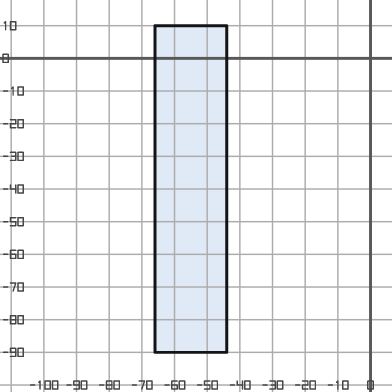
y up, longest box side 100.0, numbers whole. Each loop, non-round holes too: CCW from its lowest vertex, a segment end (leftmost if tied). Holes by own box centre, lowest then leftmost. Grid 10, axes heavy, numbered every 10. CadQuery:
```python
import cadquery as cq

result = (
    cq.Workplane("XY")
    .moveTo(-66.0, -90.0)
    .lineTo(-44.0, -90.0)
    .lineTo(-44.0, 10.0)
    .lineTo(-66.0, 10.0)
    .close()
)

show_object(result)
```